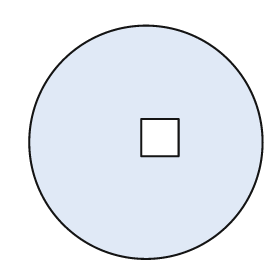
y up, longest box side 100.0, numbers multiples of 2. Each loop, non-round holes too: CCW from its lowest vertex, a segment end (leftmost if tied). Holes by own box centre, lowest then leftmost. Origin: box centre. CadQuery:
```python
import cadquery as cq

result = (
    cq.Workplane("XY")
    .moveTo(0.0, 0.0)
    .circle(50.0)
    .moveTo(-2.0, -6.0)
    .lineTo(14.0, -6.0)
    .lineTo(14.0, 10.0)
    .lineTo(-2.0, 10.0)
    .close()
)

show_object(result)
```